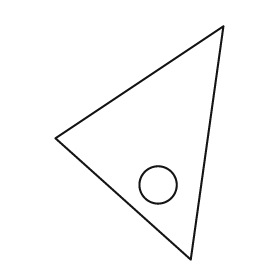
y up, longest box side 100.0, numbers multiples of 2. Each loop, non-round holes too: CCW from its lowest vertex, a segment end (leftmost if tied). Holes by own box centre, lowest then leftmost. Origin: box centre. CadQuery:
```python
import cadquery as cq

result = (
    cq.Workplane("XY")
    .moveTo(22.0, -50.0)
    .lineTo(36.0, 50.0)
    .lineTo(-36.0, 2.0)
    .close()
    .moveTo(8.0, -18.0)
    .circle(8.0)
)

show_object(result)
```